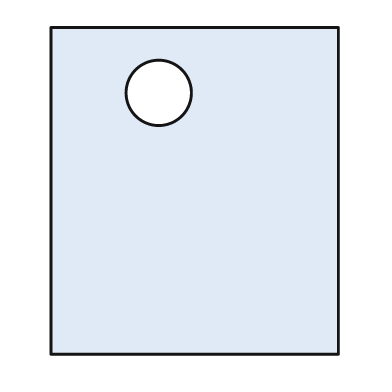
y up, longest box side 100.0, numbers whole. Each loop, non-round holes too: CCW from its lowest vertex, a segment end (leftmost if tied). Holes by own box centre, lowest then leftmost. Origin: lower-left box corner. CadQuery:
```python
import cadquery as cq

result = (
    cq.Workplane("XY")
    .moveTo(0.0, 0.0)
    .lineTo(88.0, 0.0)
    .lineTo(88.0, 100.0)
    .lineTo(0.0, 100.0)
    .close()
    .moveTo(33.0, 80.0)
    .circle(10.0)
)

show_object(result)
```